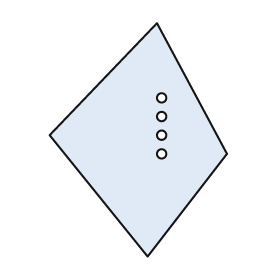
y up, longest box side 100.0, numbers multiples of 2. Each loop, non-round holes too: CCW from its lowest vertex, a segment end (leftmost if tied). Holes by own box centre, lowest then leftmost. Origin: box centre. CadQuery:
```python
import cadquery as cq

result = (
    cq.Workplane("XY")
    .moveTo(4.0, -50.0)
    .lineTo(38.0, -6.0)
    .lineTo(8.0, 50.0)
    .lineTo(-38.0, 2.0)
    .close()
    .moveTo(10.0, -6.0)
    .circle(2.0)
    .moveTo(10.0, 2.0)
    .circle(2.0)
    .moveTo(10.0, 10.0)
    .circle(2.0)
    .moveTo(10.0, 18.0)
    .circle(2.0)
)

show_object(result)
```